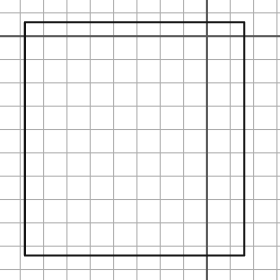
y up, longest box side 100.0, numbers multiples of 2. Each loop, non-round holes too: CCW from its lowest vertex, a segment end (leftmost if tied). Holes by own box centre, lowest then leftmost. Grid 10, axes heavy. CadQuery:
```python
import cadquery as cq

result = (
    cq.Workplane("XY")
    .moveTo(-78.0, -94.0)
    .lineTo(16.0, -94.0)
    .lineTo(16.0, 6.0)
    .lineTo(-78.0, 6.0)
    .close()
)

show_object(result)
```